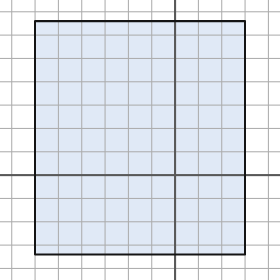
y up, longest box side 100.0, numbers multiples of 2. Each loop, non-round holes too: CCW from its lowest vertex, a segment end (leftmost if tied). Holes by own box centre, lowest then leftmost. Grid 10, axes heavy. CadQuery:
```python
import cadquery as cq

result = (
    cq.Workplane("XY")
    .moveTo(-60.0, -34.0)
    .lineTo(30.0, -34.0)
    .lineTo(30.0, 66.0)
    .lineTo(-60.0, 66.0)
    .close()
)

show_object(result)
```